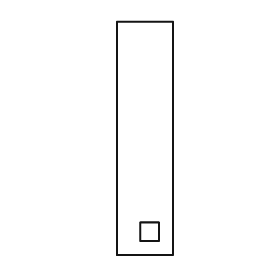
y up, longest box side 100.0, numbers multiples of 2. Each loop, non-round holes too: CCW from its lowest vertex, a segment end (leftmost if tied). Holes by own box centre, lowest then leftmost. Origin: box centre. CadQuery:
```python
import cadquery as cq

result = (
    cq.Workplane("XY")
    .moveTo(-12.0, -50.0)
    .lineTo(12.0, -50.0)
    .lineTo(12.0, 50.0)
    .lineTo(-12.0, 50.0)
    .close()
    .moveTo(-2.0, -44.0)
    .lineTo(6.0, -44.0)
    .lineTo(6.0, -36.0)
    .lineTo(-2.0, -36.0)
    .close()
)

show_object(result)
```